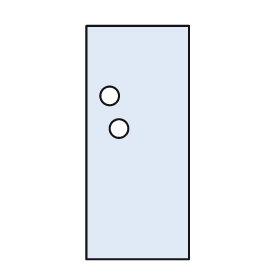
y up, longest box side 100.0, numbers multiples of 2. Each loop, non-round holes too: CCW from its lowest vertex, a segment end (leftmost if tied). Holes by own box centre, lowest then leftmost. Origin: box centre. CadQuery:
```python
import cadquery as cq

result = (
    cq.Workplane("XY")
    .moveTo(-22.0, -50.0)
    .lineTo(22.0, -50.0)
    .lineTo(22.0, 50.0)
    .lineTo(-22.0, 50.0)
    .close()
    .moveTo(-8.0, 6.0)
    .circle(4.0)
    .moveTo(-12.0, 20.0)
    .circle(4.0)
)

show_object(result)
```